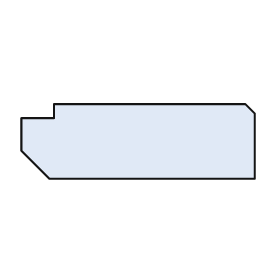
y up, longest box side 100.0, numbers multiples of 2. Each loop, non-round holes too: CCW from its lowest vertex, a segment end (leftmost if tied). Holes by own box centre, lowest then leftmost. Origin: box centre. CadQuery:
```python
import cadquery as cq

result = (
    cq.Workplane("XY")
    .moveTo(-38.0, -16.0)
    .lineTo(50.0, -16.0)
    .lineTo(50.0, 12.0)
    .lineTo(46.0, 16.0)
    .lineTo(-36.0, 16.0)
    .lineTo(-36.0, 10.0)
    .lineTo(-50.0, 10.0)
    .lineTo(-50.0, -4.0)
    .close()
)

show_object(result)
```